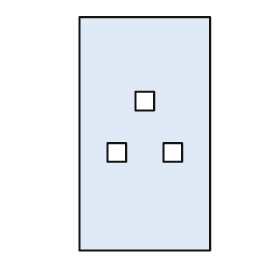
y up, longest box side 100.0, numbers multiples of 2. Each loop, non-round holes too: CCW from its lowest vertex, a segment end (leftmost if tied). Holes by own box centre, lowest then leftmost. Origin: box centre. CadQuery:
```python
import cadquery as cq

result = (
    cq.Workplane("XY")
    .moveTo(-28.0, -50.0)
    .lineTo(28.0, -50.0)
    .lineTo(28.0, 50.0)
    .lineTo(-28.0, 50.0)
    .close()
    .moveTo(-16.0, -12.0)
    .lineTo(-8.0, -12.0)
    .lineTo(-8.0, -4.0)
    .lineTo(-16.0, -4.0)
    .close()
    .moveTo(8.0, -12.0)
    .lineTo(16.0, -12.0)
    .lineTo(16.0, -4.0)
    .lineTo(8.0, -4.0)
    .close()
    .moveTo(-4.0, 10.0)
    .lineTo(4.0, 10.0)
    .lineTo(4.0, 18.0)
    .lineTo(-4.0, 18.0)
    .close()
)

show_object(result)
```